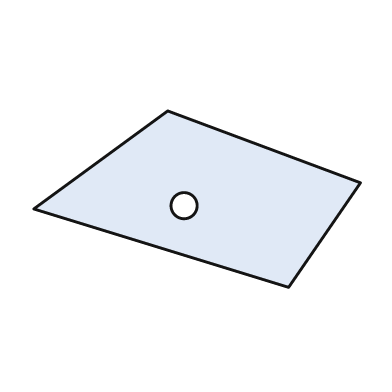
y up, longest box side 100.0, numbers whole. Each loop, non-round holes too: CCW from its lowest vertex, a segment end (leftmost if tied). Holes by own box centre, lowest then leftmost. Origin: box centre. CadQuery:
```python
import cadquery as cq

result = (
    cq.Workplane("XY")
    .moveTo(28.0, -27.0)
    .lineTo(50.0, 5.0)
    .lineTo(-9.0, 27.0)
    .lineTo(-50.0, -3.0)
    .close()
    .moveTo(-4.0, -2.0)
    .circle(4.0)
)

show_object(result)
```